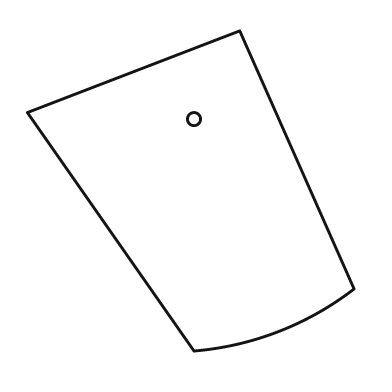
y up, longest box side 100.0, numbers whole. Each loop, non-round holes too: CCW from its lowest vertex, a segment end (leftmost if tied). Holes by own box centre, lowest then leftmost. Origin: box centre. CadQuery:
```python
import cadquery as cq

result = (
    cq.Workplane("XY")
    .moveTo(1.0, -49.0)
    .threePointArc((27.0, -43.0), (50.0, -30.0))
    .lineTo(15.0, 49.0)
    .lineTo(-50.0, 24.0)
    .close()
    .moveTo(1.0, 22.0)
    .circle(2.0)
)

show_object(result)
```